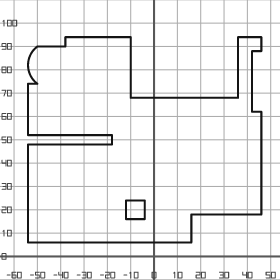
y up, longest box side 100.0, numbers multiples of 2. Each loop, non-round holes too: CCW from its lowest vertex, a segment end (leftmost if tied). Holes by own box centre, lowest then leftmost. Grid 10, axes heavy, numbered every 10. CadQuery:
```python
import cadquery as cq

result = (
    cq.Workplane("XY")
    .moveTo(-54.0, 6.0)
    .lineTo(16.0, 6.0)
    .lineTo(16.0, 18.0)
    .lineTo(46.0, 18.0)
    .lineTo(46.0, 62.0)
    .lineTo(42.0, 62.0)
    .lineTo(42.0, 88.0)
    .lineTo(46.0, 88.0)
    .lineTo(46.0, 94.0)
    .lineTo(36.0, 94.0)
    .lineTo(36.0, 68.0)
    .lineTo(-10.0, 68.0)
    .lineTo(-10.0, 94.0)
    .lineTo(-38.0, 94.0)
    .lineTo(-38.0, 90.0)
    .lineTo(-50.0, 90.0)
    .threePointArc((-54.0, 82.0), (-50.0, 74.0))
    .lineTo(-54.0, 74.0)
    .lineTo(-54.0, 52.0)
    .lineTo(-18.0, 52.0)
    .lineTo(-18.0, 48.0)
    .lineTo(-54.0, 48.0)
    .close()
    .moveTo(-12.0, 16.0)
    .lineTo(-4.0, 16.0)
    .lineTo(-4.0, 24.0)
    .lineTo(-12.0, 24.0)
    .close()
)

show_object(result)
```